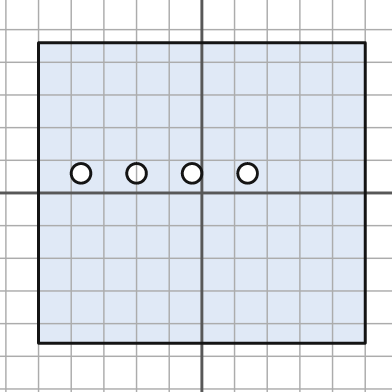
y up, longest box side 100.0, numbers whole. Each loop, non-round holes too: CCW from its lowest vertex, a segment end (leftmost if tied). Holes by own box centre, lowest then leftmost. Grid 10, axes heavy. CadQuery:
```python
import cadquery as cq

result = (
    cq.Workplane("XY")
    .moveTo(-50.0, -46.0)
    .lineTo(50.0, -46.0)
    .lineTo(50.0, 46.0)
    .lineTo(-50.0, 46.0)
    .close()
    .moveTo(-37.0, 6.0)
    .circle(3.0)
    .moveTo(-20.0, 6.0)
    .circle(3.0)
    .moveTo(-3.0, 6.0)
    .circle(3.0)
    .moveTo(14.0, 6.0)
    .circle(3.0)
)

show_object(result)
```